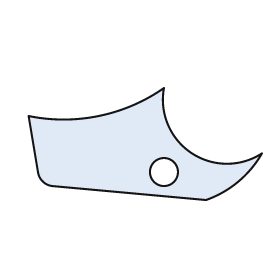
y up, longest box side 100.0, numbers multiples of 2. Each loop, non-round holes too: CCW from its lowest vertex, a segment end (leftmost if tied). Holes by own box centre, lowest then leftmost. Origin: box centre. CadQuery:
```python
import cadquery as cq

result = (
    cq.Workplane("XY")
    .moveTo(26.0, -24.0)
    .threePointArc((40.0, -16.0), (50.0, -4.0))
    .threePointArc((20.0, -4.0), (8.0, 24.0))
    .threePointArc((-20.0, 12.0), (-50.0, 12.0))
    .lineTo(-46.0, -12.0)
    .threePointArc((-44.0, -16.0), (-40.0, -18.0))
    .close()
    .moveTo(8.0, -12.0)
    .circle(6.0)
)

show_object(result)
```